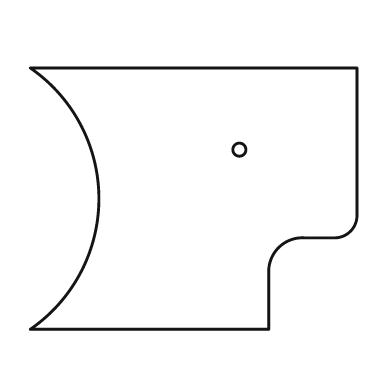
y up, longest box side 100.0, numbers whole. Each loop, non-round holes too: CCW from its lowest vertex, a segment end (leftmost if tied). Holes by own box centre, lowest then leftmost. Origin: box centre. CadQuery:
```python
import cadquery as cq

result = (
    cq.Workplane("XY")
    .moveTo(-50.0, -40.0)
    .lineTo(23.0, -40.0)
    .lineTo(23.0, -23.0)
    .threePointArc((26.0, -15.0), (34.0, -12.0))
    .lineTo(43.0, -12.0)
    .threePointArc((48.0, -10.0), (50.0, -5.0))
    .lineTo(50.0, 40.0)
    .lineTo(-50.0, 40.0)
    .threePointArc((-29.0, 0.0), (-50.0, -40.0))
    .close()
    .moveTo(14.0, 15.0)
    .circle(2.0)
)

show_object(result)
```